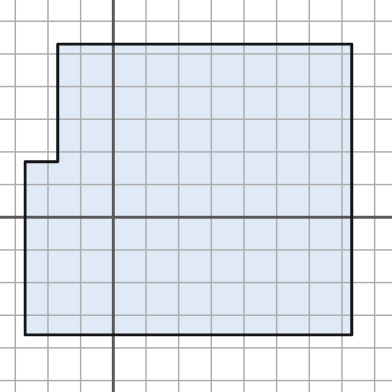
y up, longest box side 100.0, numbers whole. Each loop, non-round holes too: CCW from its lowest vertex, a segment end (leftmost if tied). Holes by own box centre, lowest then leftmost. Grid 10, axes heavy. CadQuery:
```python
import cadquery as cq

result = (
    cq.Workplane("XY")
    .moveTo(-27.0, -36.0)
    .lineTo(73.0, -36.0)
    .lineTo(73.0, 53.0)
    .lineTo(-17.0, 53.0)
    .lineTo(-17.0, 17.0)
    .lineTo(-27.0, 17.0)
    .close()
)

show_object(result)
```